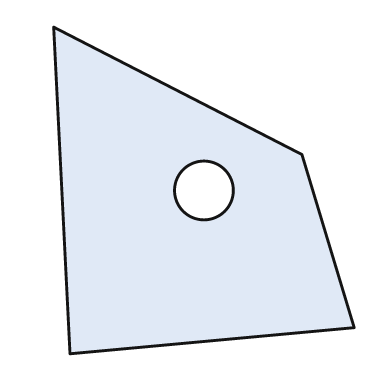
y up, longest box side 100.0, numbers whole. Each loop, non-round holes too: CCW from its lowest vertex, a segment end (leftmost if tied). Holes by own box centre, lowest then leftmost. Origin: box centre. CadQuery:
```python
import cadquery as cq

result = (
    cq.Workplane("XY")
    .moveTo(-41.0, -50.0)
    .lineTo(46.0, -42.0)
    .lineTo(30.0, 11.0)
    .lineTo(-46.0, 50.0)
    .close()
    .moveTo(0.0, 0.0)
    .circle(9.0)
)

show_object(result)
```